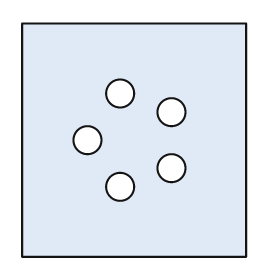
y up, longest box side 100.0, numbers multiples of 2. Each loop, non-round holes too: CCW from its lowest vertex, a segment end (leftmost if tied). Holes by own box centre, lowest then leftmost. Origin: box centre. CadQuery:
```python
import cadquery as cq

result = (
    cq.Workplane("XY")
    .moveTo(-48.0, -50.0)
    .lineTo(48.0, -50.0)
    .lineTo(48.0, 50.0)
    .lineTo(-48.0, 50.0)
    .close()
    .moveTo(-6.0, -20.0)
    .circle(6.0)
    .moveTo(16.0, -12.0)
    .circle(6.0)
    .moveTo(-20.0, 0.0)
    .circle(6.0)
    .moveTo(16.0, 12.0)
    .circle(6.0)
    .moveTo(-6.0, 20.0)
    .circle(6.0)
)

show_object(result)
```